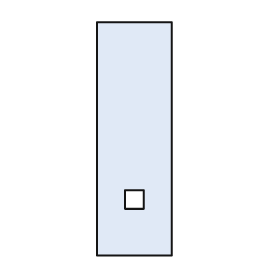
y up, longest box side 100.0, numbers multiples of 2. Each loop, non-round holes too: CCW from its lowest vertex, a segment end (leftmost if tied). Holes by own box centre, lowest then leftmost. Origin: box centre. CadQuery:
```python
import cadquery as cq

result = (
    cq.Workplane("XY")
    .moveTo(-16.0, -50.0)
    .lineTo(16.0, -50.0)
    .lineTo(16.0, 50.0)
    .lineTo(-16.0, 50.0)
    .close()
    .moveTo(-4.0, -30.0)
    .lineTo(4.0, -30.0)
    .lineTo(4.0, -22.0)
    .lineTo(-4.0, -22.0)
    .close()
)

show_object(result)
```